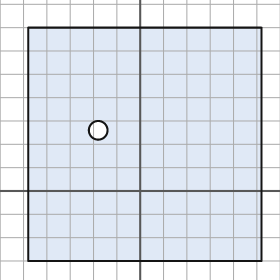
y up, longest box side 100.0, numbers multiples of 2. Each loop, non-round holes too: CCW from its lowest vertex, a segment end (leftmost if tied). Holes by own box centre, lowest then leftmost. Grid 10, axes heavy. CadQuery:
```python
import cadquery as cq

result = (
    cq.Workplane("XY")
    .moveTo(-48.0, -30.0)
    .lineTo(52.0, -30.0)
    .lineTo(52.0, 70.0)
    .lineTo(-48.0, 70.0)
    .close()
    .moveTo(-18.0, 26.0)
    .circle(4.0)
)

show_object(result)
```